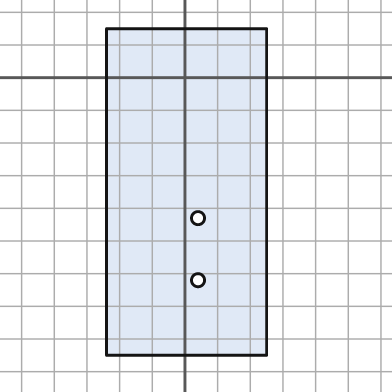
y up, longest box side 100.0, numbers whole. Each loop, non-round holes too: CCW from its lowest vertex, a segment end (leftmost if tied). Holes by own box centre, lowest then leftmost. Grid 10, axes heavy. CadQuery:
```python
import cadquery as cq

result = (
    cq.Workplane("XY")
    .moveTo(-24.0, -85.0)
    .lineTo(25.0, -85.0)
    .lineTo(25.0, 15.0)
    .lineTo(-24.0, 15.0)
    .close()
    .moveTo(4.0, -62.0)
    .circle(2.0)
    .moveTo(4.0, -43.0)
    .circle(2.0)
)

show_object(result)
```